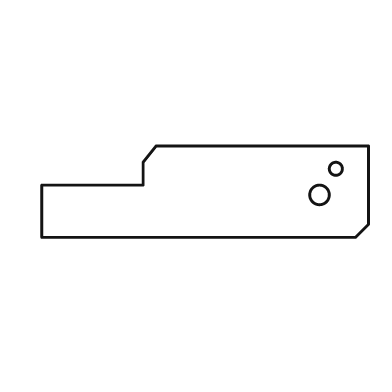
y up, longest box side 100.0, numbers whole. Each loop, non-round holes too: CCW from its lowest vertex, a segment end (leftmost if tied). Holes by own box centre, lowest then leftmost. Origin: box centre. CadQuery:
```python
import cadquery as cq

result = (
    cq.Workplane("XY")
    .moveTo(-50.0, -14.0)
    .lineTo(46.0, -14.0)
    .lineTo(50.0, -10.0)
    .lineTo(50.0, 14.0)
    .lineTo(-15.0, 14.0)
    .lineTo(-19.0, 9.0)
    .lineTo(-19.0, 2.0)
    .lineTo(-50.0, 2.0)
    .close()
    .moveTo(35.0, -1.0)
    .circle(3.0)
    .moveTo(40.0, 7.0)
    .circle(2.0)
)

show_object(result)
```